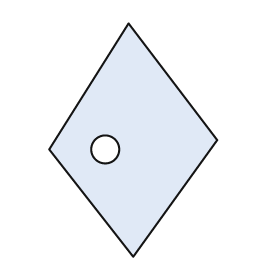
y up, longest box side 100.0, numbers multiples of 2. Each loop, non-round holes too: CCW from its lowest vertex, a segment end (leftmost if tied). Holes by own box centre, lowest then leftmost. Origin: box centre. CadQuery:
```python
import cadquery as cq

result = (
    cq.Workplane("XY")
    .moveTo(0.0, -50.0)
    .lineTo(36.0, 0.0)
    .lineTo(-2.0, 50.0)
    .lineTo(-36.0, -4.0)
    .close()
    .moveTo(-12.0, -4.0)
    .circle(6.0)
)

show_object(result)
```